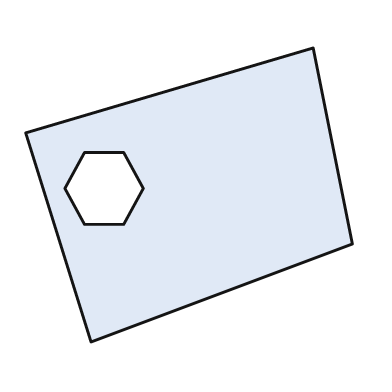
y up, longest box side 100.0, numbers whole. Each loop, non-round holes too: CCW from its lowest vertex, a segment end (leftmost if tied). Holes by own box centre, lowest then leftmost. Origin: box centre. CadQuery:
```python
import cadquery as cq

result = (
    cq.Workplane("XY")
    .moveTo(-30.0, -45.0)
    .lineTo(50.0, -15.0)
    .lineTo(38.0, 45.0)
    .lineTo(-50.0, 19.0)
    .close()
    .moveTo(-32.0, -9.0)
    .lineTo(-20.0, -9.0)
    .lineTo(-14.0, 2.0)
    .lineTo(-20.0, 13.0)
    .lineTo(-32.0, 13.0)
    .lineTo(-38.0, 2.0)
    .close()
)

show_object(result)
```